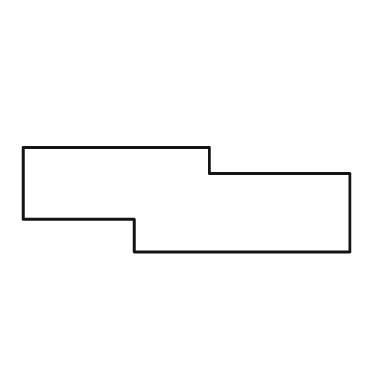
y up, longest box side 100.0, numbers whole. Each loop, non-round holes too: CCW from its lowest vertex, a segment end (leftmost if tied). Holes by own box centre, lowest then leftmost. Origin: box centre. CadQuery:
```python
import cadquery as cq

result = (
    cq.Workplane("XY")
    .moveTo(-16.0, -16.0)
    .lineTo(50.0, -16.0)
    .lineTo(50.0, 8.0)
    .lineTo(7.0, 8.0)
    .lineTo(7.0, 16.0)
    .lineTo(-50.0, 16.0)
    .lineTo(-50.0, -6.0)
    .lineTo(-16.0, -6.0)
    .close()
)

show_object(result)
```